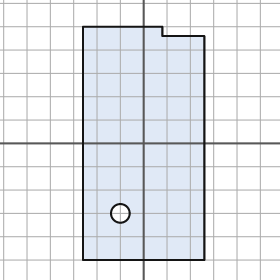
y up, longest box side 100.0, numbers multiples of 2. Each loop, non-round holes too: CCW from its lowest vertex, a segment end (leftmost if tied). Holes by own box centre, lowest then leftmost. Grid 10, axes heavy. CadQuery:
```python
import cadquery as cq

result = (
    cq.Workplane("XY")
    .moveTo(-26.0, -50.0)
    .lineTo(26.0, -50.0)
    .lineTo(26.0, 46.0)
    .lineTo(8.0, 46.0)
    .lineTo(8.0, 50.0)
    .lineTo(-26.0, 50.0)
    .close()
    .moveTo(-10.0, -30.0)
    .circle(4.0)
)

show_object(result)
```